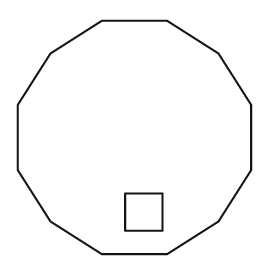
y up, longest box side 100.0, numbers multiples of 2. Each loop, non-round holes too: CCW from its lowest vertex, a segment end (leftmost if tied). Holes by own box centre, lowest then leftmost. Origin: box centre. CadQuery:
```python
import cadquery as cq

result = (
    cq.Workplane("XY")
    .moveTo(-14.0, -50.0)
    .lineTo(14.0, -50.0)
    .lineTo(36.0, -36.0)
    .lineTo(50.0, -14.0)
    .lineTo(50.0, 14.0)
    .lineTo(36.0, 36.0)
    .lineTo(14.0, 50.0)
    .lineTo(-14.0, 50.0)
    .lineTo(-36.0, 36.0)
    .lineTo(-50.0, 14.0)
    .lineTo(-50.0, -14.0)
    .lineTo(-36.0, -36.0)
    .close()
    .moveTo(-4.0, -40.0)
    .lineTo(12.0, -40.0)
    .lineTo(12.0, -24.0)
    .lineTo(-4.0, -24.0)
    .close()
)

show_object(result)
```